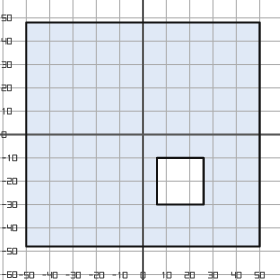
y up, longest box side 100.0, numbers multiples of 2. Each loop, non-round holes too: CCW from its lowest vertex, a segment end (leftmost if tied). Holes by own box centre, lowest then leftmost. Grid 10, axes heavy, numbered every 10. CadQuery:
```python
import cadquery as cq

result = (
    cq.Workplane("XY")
    .moveTo(-50.0, -48.0)
    .lineTo(50.0, -48.0)
    .lineTo(50.0, 48.0)
    .lineTo(-50.0, 48.0)
    .close()
    .moveTo(6.0, -30.0)
    .lineTo(26.0, -30.0)
    .lineTo(26.0, -10.0)
    .lineTo(6.0, -10.0)
    .close()
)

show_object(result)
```